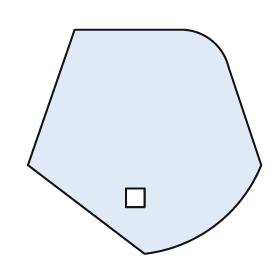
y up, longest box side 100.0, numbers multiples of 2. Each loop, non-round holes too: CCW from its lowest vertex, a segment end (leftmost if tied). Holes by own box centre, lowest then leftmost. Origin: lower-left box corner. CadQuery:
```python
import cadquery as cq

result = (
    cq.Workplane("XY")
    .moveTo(50.0, 0.0)
    .threePointArc((80.0, 12.0), (100.0, 38.0))
    .lineTo(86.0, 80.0)
    .threePointArc((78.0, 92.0), (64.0, 96.0))
    .lineTo(20.0, 96.0)
    .lineTo(0.0, 38.0)
    .close()
    .moveTo(42.0, 20.0)
    .lineTo(50.0, 20.0)
    .lineTo(50.0, 28.0)
    .lineTo(42.0, 28.0)
    .close()
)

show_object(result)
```